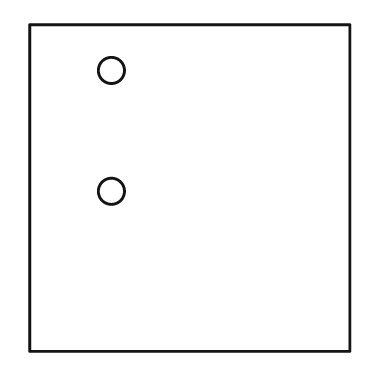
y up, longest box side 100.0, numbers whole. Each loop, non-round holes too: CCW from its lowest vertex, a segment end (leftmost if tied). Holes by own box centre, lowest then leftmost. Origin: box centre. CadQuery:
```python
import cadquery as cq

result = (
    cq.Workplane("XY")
    .moveTo(-49.0, -50.0)
    .lineTo(49.0, -50.0)
    .lineTo(49.0, 50.0)
    .lineTo(-49.0, 50.0)
    .close()
    .moveTo(-24.0, -1.0)
    .circle(4.0)
    .moveTo(-24.0, 36.0)
    .circle(4.0)
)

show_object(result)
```